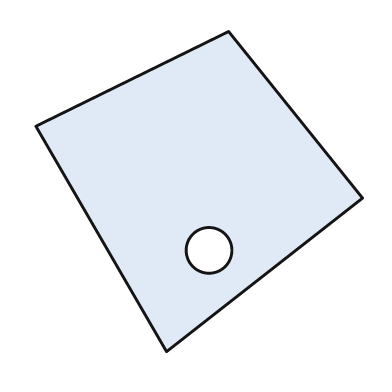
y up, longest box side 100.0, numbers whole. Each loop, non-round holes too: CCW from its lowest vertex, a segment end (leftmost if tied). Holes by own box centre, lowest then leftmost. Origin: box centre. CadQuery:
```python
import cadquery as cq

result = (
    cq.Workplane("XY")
    .moveTo(-10.0, -49.0)
    .lineTo(50.0, -2.0)
    .lineTo(9.0, 49.0)
    .lineTo(-50.0, 20.0)
    .close()
    .moveTo(3.0, -18.0)
    .circle(7.0)
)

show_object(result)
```